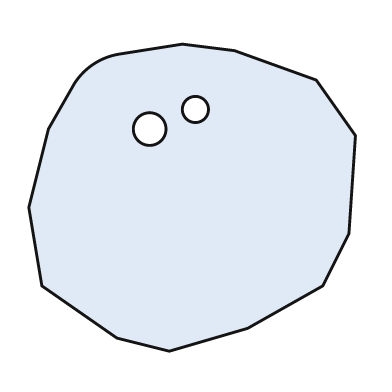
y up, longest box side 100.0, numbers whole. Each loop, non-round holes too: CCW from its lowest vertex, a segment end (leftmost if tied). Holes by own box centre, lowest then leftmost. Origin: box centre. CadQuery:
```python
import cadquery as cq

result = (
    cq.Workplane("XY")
    .moveTo(-7.0, -47.0)
    .lineTo(17.0, -40.0)
    .lineTo(40.0, -27.0)
    .lineTo(48.0, -11.0)
    .lineTo(50.0, 19.0)
    .lineTo(38.0, 36.0)
    .lineTo(13.0, 45.0)
    .lineTo(-3.0, 47.0)
    .lineTo(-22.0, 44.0)
    .threePointArc((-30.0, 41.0), (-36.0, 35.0))
    .lineTo(-44.0, 21.0)
    .lineTo(-50.0, -3.0)
    .lineTo(-46.0, -27.0)
    .lineTo(-23.0, -43.0)
    .close()
    .moveTo(-13.0, 21.0)
    .circle(5.0)
    .moveTo(1.0, 27.0)
    .circle(4.0)
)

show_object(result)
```